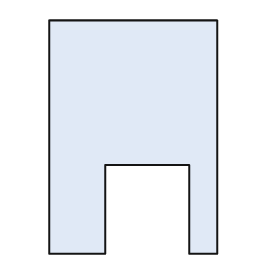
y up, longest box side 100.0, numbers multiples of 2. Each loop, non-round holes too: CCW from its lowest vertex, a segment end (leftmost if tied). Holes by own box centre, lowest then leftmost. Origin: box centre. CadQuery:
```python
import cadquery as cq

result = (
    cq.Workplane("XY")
    .moveTo(-36.0, -50.0)
    .lineTo(-12.0, -50.0)
    .lineTo(-12.0, -12.0)
    .lineTo(24.0, -12.0)
    .lineTo(24.0, -50.0)
    .lineTo(36.0, -50.0)
    .lineTo(36.0, 50.0)
    .lineTo(-36.0, 50.0)
    .close()
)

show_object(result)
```